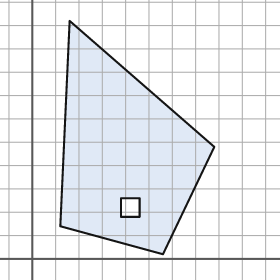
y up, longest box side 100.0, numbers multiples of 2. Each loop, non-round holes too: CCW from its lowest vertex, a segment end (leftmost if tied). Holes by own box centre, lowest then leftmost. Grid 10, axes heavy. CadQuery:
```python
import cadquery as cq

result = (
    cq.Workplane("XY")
    .moveTo(56.0, 2.0)
    .lineTo(78.0, 48.0)
    .lineTo(16.0, 102.0)
    .lineTo(12.0, 14.0)
    .close()
    .moveTo(38.0, 18.0)
    .lineTo(46.0, 18.0)
    .lineTo(46.0, 26.0)
    .lineTo(38.0, 26.0)
    .close()
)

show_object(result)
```